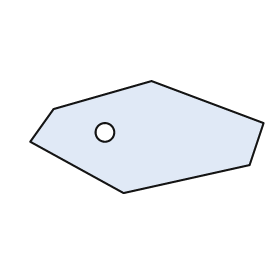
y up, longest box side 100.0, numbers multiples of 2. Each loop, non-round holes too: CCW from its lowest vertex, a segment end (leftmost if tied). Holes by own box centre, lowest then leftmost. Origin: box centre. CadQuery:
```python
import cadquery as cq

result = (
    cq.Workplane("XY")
    .moveTo(-10.0, -24.0)
    .lineTo(44.0, -12.0)
    .lineTo(50.0, 6.0)
    .lineTo(2.0, 24.0)
    .lineTo(-40.0, 12.0)
    .lineTo(-50.0, -2.0)
    .close()
    .moveTo(-18.0, 2.0)
    .circle(4.0)
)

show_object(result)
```